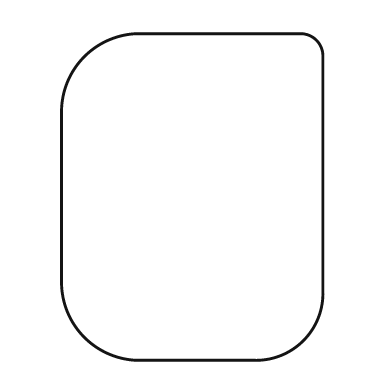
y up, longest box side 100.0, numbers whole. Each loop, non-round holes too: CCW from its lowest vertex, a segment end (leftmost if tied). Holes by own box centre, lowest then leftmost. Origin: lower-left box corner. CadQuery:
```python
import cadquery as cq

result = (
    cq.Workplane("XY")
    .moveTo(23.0, 0.0)
    .lineTo(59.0, 0.0)
    .threePointArc((74.0, 6.0), (80.0, 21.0))
    .lineTo(80.0, 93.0)
    .threePointArc((78.0, 98.0), (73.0, 100.0))
    .lineTo(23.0, 100.0)
    .threePointArc((7.0, 93.0), (0.0, 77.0))
    .lineTo(0.0, 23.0)
    .threePointArc((7.0, 7.0), (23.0, 0.0))
    .close()
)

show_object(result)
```